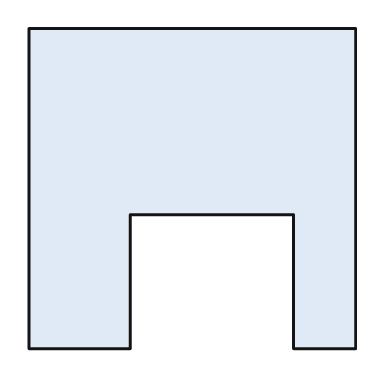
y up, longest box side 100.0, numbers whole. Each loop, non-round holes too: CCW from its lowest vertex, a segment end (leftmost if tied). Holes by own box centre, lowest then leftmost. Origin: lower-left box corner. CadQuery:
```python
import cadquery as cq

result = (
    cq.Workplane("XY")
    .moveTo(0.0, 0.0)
    .lineTo(31.0, 0.0)
    .lineTo(31.0, 41.0)
    .lineTo(81.0, 41.0)
    .lineTo(81.0, 0.0)
    .lineTo(100.0, 0.0)
    .lineTo(100.0, 98.0)
    .lineTo(0.0, 98.0)
    .close()
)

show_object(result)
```